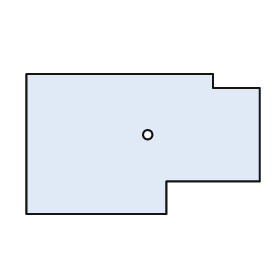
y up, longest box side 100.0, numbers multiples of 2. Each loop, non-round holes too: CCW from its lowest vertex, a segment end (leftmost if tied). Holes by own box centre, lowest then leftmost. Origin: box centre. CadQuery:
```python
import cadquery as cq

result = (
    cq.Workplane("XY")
    .moveTo(-50.0, -30.0)
    .lineTo(10.0, -30.0)
    .lineTo(10.0, -16.0)
    .lineTo(50.0, -16.0)
    .lineTo(50.0, 24.0)
    .lineTo(30.0, 24.0)
    .lineTo(30.0, 30.0)
    .lineTo(-50.0, 30.0)
    .close()
    .moveTo(2.0, 4.0)
    .circle(2.0)
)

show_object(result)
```